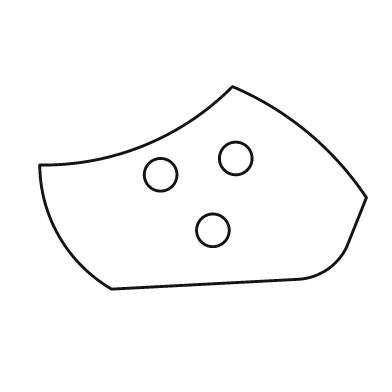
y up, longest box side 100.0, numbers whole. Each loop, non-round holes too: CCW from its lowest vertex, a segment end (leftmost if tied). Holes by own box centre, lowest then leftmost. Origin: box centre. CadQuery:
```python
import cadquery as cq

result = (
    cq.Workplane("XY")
    .moveTo(-28.0, -31.0)
    .lineTo(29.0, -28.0)
    .threePointArc((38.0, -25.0), (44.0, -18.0))
    .lineTo(50.0, -3.0)
    .threePointArc((32.0, 17.0), (9.0, 31.0))
    .threePointArc((-18.0, 13.0), (-50.0, 7.0))
    .threePointArc((-44.0, -15.0), (-28.0, -31.0))
    .close()
    .moveTo(3.0, -13.0)
    .circle(5.0)
    .moveTo(-13.0, 4.0)
    .circle(5.0)
    .moveTo(10.0, 9.0)
    .circle(5.0)
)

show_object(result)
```